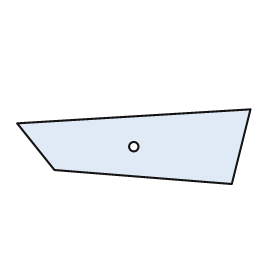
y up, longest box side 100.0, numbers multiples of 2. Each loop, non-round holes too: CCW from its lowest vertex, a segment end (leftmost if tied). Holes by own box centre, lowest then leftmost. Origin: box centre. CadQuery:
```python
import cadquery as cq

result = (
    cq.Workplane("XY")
    .moveTo(42.0, -16.0)
    .lineTo(50.0, 16.0)
    .lineTo(-50.0, 10.0)
    .lineTo(-34.0, -10.0)
    .close()
    .moveTo(0.0, 0.0)
    .circle(2.0)
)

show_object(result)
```